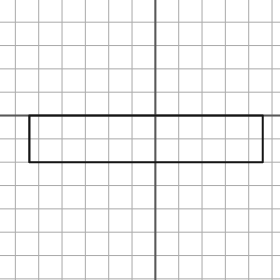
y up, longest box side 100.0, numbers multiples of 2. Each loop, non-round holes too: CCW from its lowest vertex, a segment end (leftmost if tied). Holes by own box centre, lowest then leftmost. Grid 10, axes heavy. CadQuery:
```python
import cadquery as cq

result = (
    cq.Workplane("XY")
    .moveTo(-54.0, -20.0)
    .lineTo(46.0, -20.0)
    .lineTo(46.0, 0.0)
    .lineTo(-54.0, 0.0)
    .close()
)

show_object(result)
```